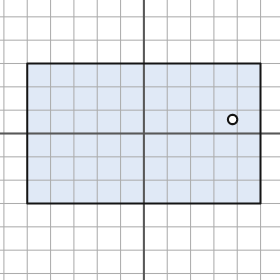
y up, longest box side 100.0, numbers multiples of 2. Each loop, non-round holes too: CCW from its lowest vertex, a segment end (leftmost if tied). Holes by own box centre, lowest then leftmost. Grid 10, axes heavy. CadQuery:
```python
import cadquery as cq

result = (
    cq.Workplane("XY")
    .moveTo(-50.0, -30.0)
    .lineTo(50.0, -30.0)
    .lineTo(50.0, 30.0)
    .lineTo(-50.0, 30.0)
    .close()
    .moveTo(38.0, 6.0)
    .circle(2.0)
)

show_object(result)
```